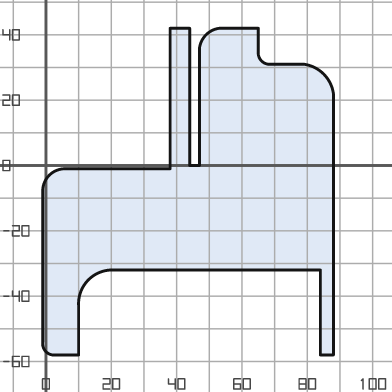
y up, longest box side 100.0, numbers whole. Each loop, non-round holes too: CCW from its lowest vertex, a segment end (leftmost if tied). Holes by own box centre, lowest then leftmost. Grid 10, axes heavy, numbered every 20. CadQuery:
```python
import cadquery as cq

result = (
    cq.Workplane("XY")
    .moveTo(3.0, -58.0)
    .lineTo(10.0, -58.0)
    .lineTo(10.0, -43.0)
    .threePointArc((13.0, -35.0), (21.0, -32.0))
    .lineTo(84.0, -32.0)
    .lineTo(84.0, -58.0)
    .lineTo(88.0, -58.0)
    .lineTo(88.0, 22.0)
    .threePointArc((85.0, 28.0), (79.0, 31.0))
    .lineTo(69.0, 31.0)
    .threePointArc((66.0, 32.0), (65.0, 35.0))
    .lineTo(65.0, 42.0)
    .lineTo(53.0, 42.0)
    .threePointArc((49.0, 40.0), (47.0, 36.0))
    .lineTo(47.0, 0.0)
    .lineTo(44.0, 0.0)
    .lineTo(44.0, 42.0)
    .lineTo(38.0, 42.0)
    .lineTo(38.0, -1.0)
    .lineTo(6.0, -1.0)
    .threePointArc((1.0, -3.0), (-1.0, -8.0))
    .lineTo(-1.0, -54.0)
    .threePointArc((0.0, -57.0), (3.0, -58.0))
    .close()
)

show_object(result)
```